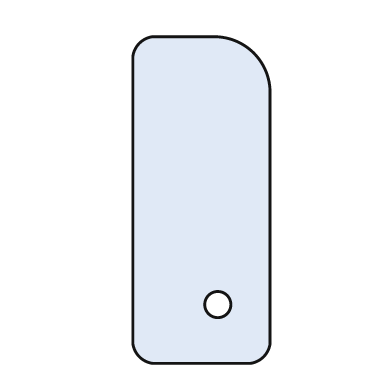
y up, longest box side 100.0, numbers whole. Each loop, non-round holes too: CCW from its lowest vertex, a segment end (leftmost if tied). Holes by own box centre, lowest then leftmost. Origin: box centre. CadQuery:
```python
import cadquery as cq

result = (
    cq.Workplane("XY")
    .moveTo(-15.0, -50.0)
    .lineTo(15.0, -50.0)
    .threePointArc((19.0, -48.0), (21.0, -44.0))
    .lineTo(21.0, 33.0)
    .threePointArc((16.0, 45.0), (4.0, 50.0))
    .lineTo(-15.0, 50.0)
    .threePointArc((-19.0, 48.0), (-21.0, 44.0))
    .lineTo(-21.0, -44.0)
    .threePointArc((-19.0, -48.0), (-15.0, -50.0))
    .close()
    .moveTo(5.0, -32.0)
    .circle(4.0)
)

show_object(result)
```